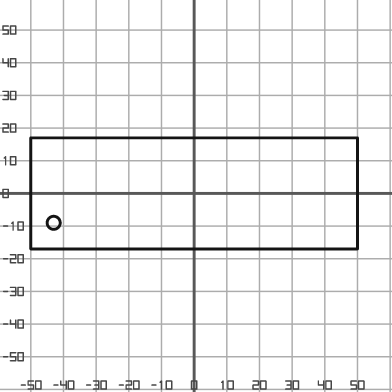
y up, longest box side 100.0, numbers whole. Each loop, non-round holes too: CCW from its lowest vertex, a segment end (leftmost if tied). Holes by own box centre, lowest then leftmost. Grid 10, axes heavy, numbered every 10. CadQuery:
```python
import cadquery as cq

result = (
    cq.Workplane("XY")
    .moveTo(-50.0, -17.0)
    .lineTo(50.0, -17.0)
    .lineTo(50.0, 17.0)
    .lineTo(-50.0, 17.0)
    .close()
    .moveTo(-43.0, -9.0)
    .circle(2.0)
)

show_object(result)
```